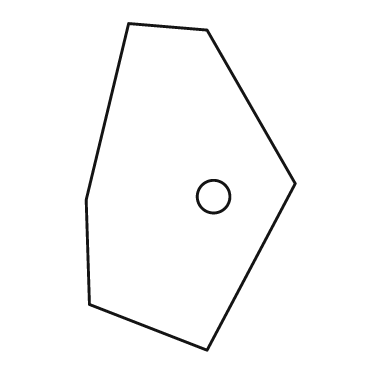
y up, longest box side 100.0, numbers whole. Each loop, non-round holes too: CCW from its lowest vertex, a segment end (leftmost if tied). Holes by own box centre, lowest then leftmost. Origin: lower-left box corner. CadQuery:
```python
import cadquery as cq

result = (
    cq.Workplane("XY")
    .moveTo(37.0, 0.0)
    .lineTo(64.0, 51.0)
    .lineTo(37.0, 98.0)
    .lineTo(13.0, 100.0)
    .lineTo(0.0, 46.0)
    .lineTo(1.0, 14.0)
    .close()
    .moveTo(39.0, 47.0)
    .circle(5.0)
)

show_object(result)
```